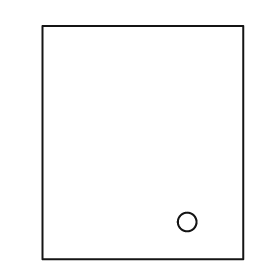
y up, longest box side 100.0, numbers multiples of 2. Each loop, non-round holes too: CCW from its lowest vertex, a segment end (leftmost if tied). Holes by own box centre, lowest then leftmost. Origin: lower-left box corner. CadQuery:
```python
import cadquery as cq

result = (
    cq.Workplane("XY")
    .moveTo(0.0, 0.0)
    .lineTo(86.0, 0.0)
    .lineTo(86.0, 100.0)
    .lineTo(0.0, 100.0)
    .close()
    .moveTo(62.0, 16.0)
    .circle(4.0)
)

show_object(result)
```